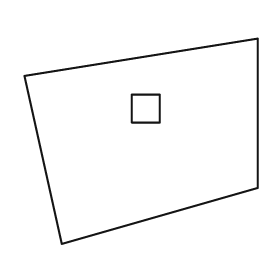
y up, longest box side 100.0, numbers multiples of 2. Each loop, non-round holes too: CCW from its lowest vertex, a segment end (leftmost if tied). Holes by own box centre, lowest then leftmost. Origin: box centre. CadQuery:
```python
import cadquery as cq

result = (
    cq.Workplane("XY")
    .moveTo(-34.0, -44.0)
    .lineTo(50.0, -20.0)
    .lineTo(50.0, 44.0)
    .lineTo(-50.0, 28.0)
    .close()
    .moveTo(-4.0, 8.0)
    .lineTo(8.0, 8.0)
    .lineTo(8.0, 20.0)
    .lineTo(-4.0, 20.0)
    .close()
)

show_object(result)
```